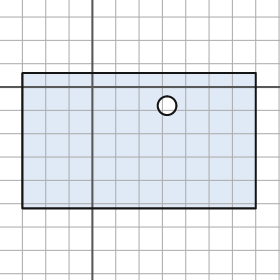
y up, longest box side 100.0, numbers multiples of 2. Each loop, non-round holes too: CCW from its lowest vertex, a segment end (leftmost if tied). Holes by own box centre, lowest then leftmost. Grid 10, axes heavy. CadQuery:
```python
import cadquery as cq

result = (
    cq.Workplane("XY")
    .moveTo(-30.0, -52.0)
    .lineTo(70.0, -52.0)
    .lineTo(70.0, 6.0)
    .lineTo(-30.0, 6.0)
    .close()
    .moveTo(32.0, -8.0)
    .circle(4.0)
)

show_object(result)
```